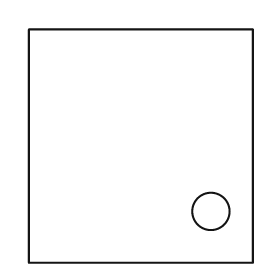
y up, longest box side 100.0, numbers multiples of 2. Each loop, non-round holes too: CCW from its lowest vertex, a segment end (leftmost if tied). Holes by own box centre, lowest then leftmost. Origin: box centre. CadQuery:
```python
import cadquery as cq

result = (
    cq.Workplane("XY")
    .moveTo(-48.0, -50.0)
    .lineTo(48.0, -50.0)
    .lineTo(48.0, 50.0)
    .lineTo(-48.0, 50.0)
    .close()
    .moveTo(30.0, -28.0)
    .circle(8.0)
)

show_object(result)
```